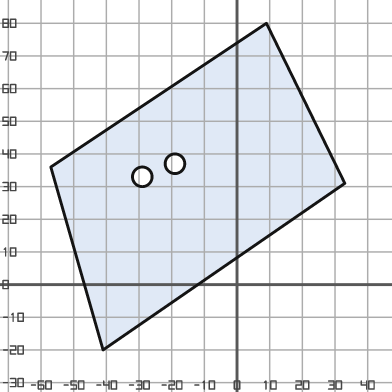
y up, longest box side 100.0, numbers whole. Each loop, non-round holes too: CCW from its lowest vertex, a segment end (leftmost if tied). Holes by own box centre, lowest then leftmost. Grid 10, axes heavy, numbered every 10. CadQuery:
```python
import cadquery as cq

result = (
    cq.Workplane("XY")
    .moveTo(-41.0, -20.0)
    .lineTo(33.0, 31.0)
    .lineTo(9.0, 80.0)
    .lineTo(-57.0, 36.0)
    .close()
    .moveTo(-29.0, 33.0)
    .circle(3.0)
    .moveTo(-19.0, 37.0)
    .circle(3.0)
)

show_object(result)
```